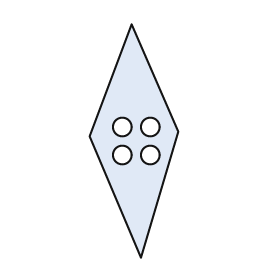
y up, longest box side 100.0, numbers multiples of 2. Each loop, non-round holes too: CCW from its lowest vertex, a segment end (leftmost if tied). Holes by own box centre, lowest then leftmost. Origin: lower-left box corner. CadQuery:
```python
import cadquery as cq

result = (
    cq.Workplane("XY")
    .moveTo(22.0, 0.0)
    .lineTo(38.0, 54.0)
    .lineTo(18.0, 100.0)
    .lineTo(0.0, 52.0)
    .close()
    .moveTo(14.0, 44.0)
    .circle(4.0)
    .moveTo(26.0, 44.0)
    .circle(4.0)
    .moveTo(14.0, 56.0)
    .circle(4.0)
    .moveTo(26.0, 56.0)
    .circle(4.0)
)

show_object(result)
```